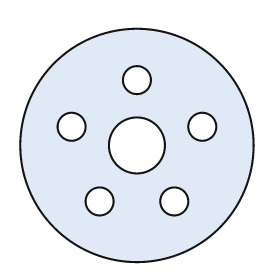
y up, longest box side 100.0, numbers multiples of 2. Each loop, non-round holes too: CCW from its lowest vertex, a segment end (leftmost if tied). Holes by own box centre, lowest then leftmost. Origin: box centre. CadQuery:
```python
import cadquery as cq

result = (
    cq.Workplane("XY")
    .moveTo(0.0, 0.0)
    .circle(50.0)
    .moveTo(-16.0, -24.0)
    .circle(6.0)
    .moveTo(16.0, -24.0)
    .circle(6.0)
    .moveTo(0.0, 0.0)
    .circle(12.0)
    .moveTo(-28.0, 8.0)
    .circle(6.0)
    .moveTo(28.0, 8.0)
    .circle(6.0)
    .moveTo(0.0, 28.0)
    .circle(6.0)
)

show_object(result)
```